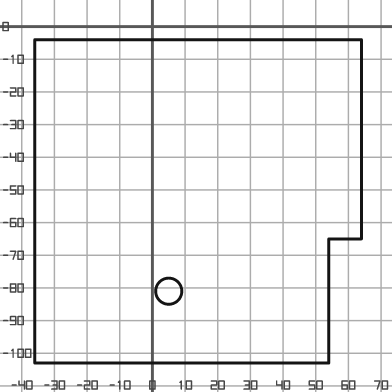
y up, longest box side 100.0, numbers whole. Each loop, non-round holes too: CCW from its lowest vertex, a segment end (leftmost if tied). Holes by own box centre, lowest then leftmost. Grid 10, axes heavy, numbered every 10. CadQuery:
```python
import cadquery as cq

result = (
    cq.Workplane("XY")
    .moveTo(-36.0, -103.0)
    .lineTo(54.0, -103.0)
    .lineTo(54.0, -65.0)
    .lineTo(64.0, -65.0)
    .lineTo(64.0, -4.0)
    .lineTo(-36.0, -4.0)
    .close()
    .moveTo(5.0, -81.0)
    .circle(4.0)
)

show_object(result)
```